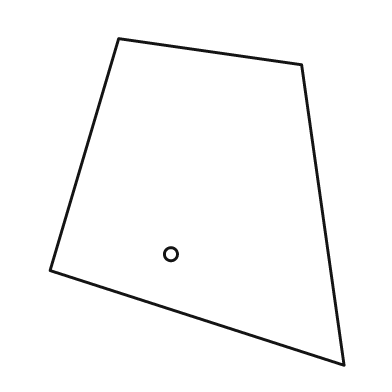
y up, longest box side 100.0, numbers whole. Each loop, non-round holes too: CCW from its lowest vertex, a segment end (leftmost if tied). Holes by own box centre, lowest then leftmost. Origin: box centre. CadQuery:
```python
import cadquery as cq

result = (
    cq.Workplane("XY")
    .moveTo(45.0, -50.0)
    .lineTo(32.0, 42.0)
    .lineTo(-24.0, 50.0)
    .lineTo(-45.0, -21.0)
    .close()
    .moveTo(-8.0, -16.0)
    .circle(2.0)
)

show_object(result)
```